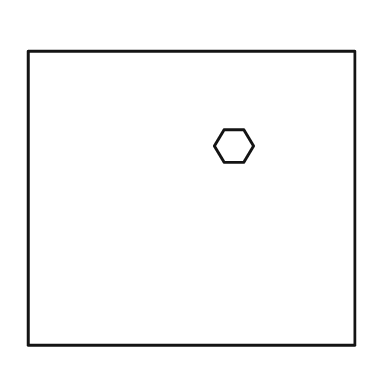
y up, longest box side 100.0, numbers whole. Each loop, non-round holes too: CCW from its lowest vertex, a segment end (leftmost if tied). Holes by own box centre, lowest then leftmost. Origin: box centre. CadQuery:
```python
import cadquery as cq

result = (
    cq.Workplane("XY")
    .moveTo(-50.0, -45.0)
    .lineTo(50.0, -45.0)
    .lineTo(50.0, 45.0)
    .lineTo(-50.0, 45.0)
    .close()
    .moveTo(10.0, 11.0)
    .lineTo(16.0, 11.0)
    .lineTo(19.0, 16.0)
    .lineTo(16.0, 21.0)
    .lineTo(10.0, 21.0)
    .lineTo(7.0, 16.0)
    .close()
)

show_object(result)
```